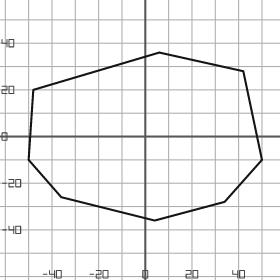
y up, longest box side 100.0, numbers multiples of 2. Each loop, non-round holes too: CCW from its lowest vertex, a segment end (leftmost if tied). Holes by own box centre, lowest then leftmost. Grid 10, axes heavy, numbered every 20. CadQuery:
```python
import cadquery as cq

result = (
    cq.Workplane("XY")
    .moveTo(4.0, -36.0)
    .lineTo(34.0, -28.0)
    .lineTo(50.0, -10.0)
    .lineTo(42.0, 28.0)
    .lineTo(6.0, 36.0)
    .lineTo(-48.0, 20.0)
    .lineTo(-50.0, -10.0)
    .lineTo(-36.0, -26.0)
    .close()
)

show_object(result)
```